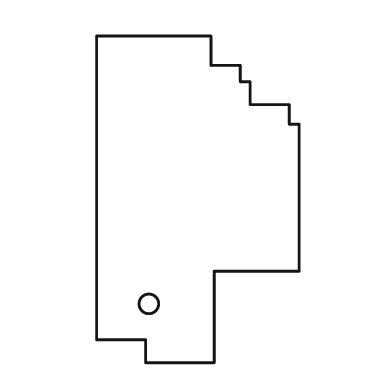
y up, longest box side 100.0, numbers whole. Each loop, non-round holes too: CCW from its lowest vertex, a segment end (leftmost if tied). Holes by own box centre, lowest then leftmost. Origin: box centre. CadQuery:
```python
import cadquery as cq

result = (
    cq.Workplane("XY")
    .moveTo(-16.0, -50.0)
    .lineTo(5.0, -50.0)
    .lineTo(5.0, -22.0)
    .lineTo(31.0, -22.0)
    .lineTo(31.0, 23.0)
    .lineTo(28.0, 23.0)
    .lineTo(28.0, 29.0)
    .lineTo(16.0, 29.0)
    .lineTo(16.0, 36.0)
    .lineTo(13.0, 36.0)
    .lineTo(13.0, 41.0)
    .lineTo(4.0, 41.0)
    .lineTo(4.0, 50.0)
    .lineTo(-31.0, 50.0)
    .lineTo(-31.0, -43.0)
    .lineTo(-16.0, -43.0)
    .close()
    .moveTo(-15.0, -32.0)
    .circle(3.0)
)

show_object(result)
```